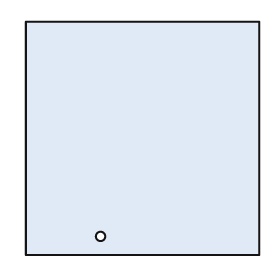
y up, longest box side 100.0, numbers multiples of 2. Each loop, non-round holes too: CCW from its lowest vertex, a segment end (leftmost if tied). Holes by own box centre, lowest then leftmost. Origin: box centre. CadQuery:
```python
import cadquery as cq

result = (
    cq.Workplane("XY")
    .moveTo(-50.0, -50.0)
    .lineTo(50.0, -50.0)
    .lineTo(50.0, 50.0)
    .lineTo(-50.0, 50.0)
    .close()
    .moveTo(-18.0, -42.0)
    .circle(2.0)
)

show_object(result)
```